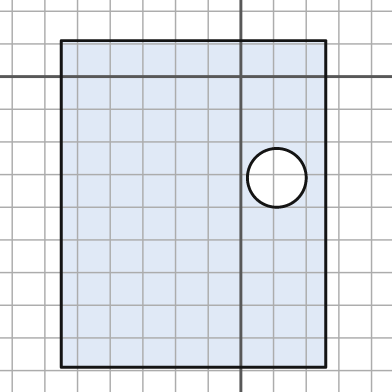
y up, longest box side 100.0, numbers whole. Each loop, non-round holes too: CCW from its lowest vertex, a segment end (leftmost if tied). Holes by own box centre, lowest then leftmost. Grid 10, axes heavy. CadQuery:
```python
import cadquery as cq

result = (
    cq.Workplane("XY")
    .moveTo(-55.0, -89.0)
    .lineTo(26.0, -89.0)
    .lineTo(26.0, 11.0)
    .lineTo(-55.0, 11.0)
    .close()
    .moveTo(11.0, -31.0)
    .circle(9.0)
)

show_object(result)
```